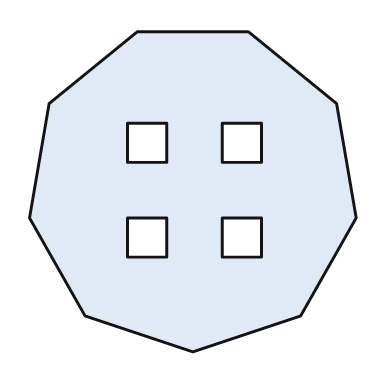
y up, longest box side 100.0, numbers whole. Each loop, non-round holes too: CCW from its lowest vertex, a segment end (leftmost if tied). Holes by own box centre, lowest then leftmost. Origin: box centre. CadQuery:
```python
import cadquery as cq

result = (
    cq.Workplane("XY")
    .moveTo(0.0, -49.0)
    .lineTo(33.0, -38.0)
    .lineTo(50.0, -8.0)
    .lineTo(44.0, 27.0)
    .lineTo(17.0, 49.0)
    .lineTo(-17.0, 49.0)
    .lineTo(-44.0, 27.0)
    .lineTo(-50.0, -8.0)
    .lineTo(-33.0, -38.0)
    .close()
    .moveTo(-20.0, -20.0)
    .lineTo(-8.0, -20.0)
    .lineTo(-8.0, -8.0)
    .lineTo(-20.0, -8.0)
    .close()
    .moveTo(9.0, -20.0)
    .lineTo(21.0, -20.0)
    .lineTo(21.0, -8.0)
    .lineTo(9.0, -8.0)
    .close()
    .moveTo(-20.0, 9.0)
    .lineTo(-8.0, 9.0)
    .lineTo(-8.0, 21.0)
    .lineTo(-20.0, 21.0)
    .close()
    .moveTo(9.0, 9.0)
    .lineTo(21.0, 9.0)
    .lineTo(21.0, 21.0)
    .lineTo(9.0, 21.0)
    .close()
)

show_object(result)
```